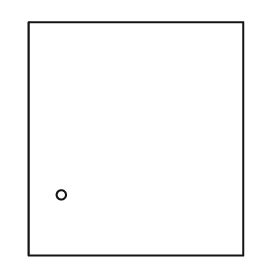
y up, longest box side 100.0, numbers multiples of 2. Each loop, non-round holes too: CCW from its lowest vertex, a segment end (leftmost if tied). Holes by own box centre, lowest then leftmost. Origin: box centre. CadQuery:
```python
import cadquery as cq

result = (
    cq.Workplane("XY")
    .moveTo(-46.0, -50.0)
    .lineTo(46.0, -50.0)
    .lineTo(46.0, 50.0)
    .lineTo(-46.0, 50.0)
    .close()
    .moveTo(-32.0, -24.0)
    .circle(2.0)
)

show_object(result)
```